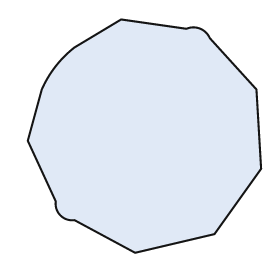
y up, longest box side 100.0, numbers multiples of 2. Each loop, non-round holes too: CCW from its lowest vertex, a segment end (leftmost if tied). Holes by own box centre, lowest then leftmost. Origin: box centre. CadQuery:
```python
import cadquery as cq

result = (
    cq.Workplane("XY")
    .moveTo(-4.0, -50.0)
    .lineTo(30.0, -42.0)
    .lineTo(50.0, -14.0)
    .lineTo(48.0, 20.0)
    .lineTo(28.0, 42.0)
    .threePointArc((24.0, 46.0), (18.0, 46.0))
    .lineTo(-10.0, 50.0)
    .lineTo(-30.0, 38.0)
    .threePointArc((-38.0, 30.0), (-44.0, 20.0))
    .lineTo(-50.0, -2.0)
    .lineTo(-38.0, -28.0)
    .threePointArc((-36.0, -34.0), (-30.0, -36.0))
    .close()
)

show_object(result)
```